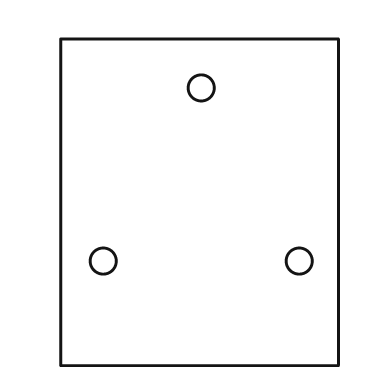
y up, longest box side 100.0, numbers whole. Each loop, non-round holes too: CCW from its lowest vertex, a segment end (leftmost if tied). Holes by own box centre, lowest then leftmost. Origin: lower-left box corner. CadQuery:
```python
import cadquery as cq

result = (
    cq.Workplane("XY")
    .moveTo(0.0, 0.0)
    .lineTo(85.0, 0.0)
    .lineTo(85.0, 100.0)
    .lineTo(0.0, 100.0)
    .close()
    .moveTo(13.0, 32.0)
    .circle(4.0)
    .moveTo(73.0, 32.0)
    .circle(4.0)
    .moveTo(43.0, 85.0)
    .circle(4.0)
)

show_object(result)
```